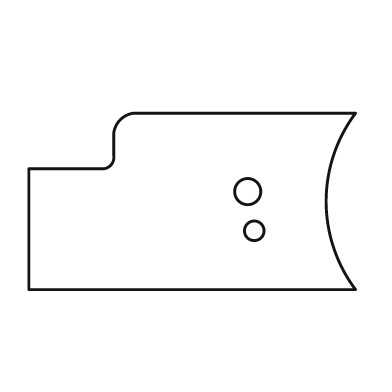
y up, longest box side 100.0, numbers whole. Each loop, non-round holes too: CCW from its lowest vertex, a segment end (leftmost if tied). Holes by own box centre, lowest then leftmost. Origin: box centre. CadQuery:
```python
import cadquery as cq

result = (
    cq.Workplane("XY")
    .moveTo(-50.0, -27.0)
    .lineTo(50.0, -27.0)
    .threePointArc((41.0, 0.0), (50.0, 27.0))
    .lineTo(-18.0, 27.0)
    .threePointArc((-22.0, 25.0), (-24.0, 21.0))
    .lineTo(-24.0, 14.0)
    .threePointArc((-25.0, 11.0), (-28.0, 10.0))
    .lineTo(-50.0, 10.0)
    .close()
    .moveTo(19.0, -9.0)
    .circle(3.0)
    .moveTo(17.0, 3.0)
    .circle(4.0)
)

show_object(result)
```